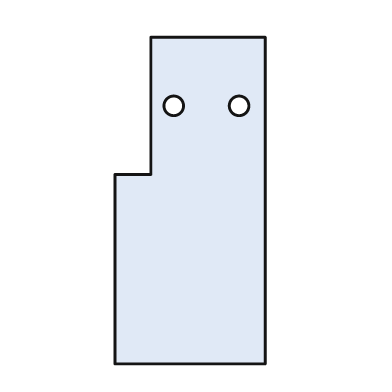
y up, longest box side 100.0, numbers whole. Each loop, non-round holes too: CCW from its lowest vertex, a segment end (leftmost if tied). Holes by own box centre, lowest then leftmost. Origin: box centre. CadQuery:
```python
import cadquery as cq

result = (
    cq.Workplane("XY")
    .moveTo(-23.0, -50.0)
    .lineTo(23.0, -50.0)
    .lineTo(23.0, 50.0)
    .lineTo(-12.0, 50.0)
    .lineTo(-12.0, 8.0)
    .lineTo(-23.0, 8.0)
    .close()
    .moveTo(-5.0, 29.0)
    .circle(3.0)
    .moveTo(15.0, 29.0)
    .circle(3.0)
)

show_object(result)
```